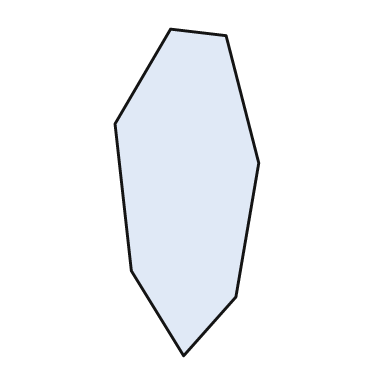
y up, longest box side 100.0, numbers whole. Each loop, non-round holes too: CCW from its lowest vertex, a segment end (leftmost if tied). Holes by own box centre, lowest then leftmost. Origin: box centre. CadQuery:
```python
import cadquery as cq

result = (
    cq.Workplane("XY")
    .moveTo(-1.0, -50.0)
    .lineTo(15.0, -32.0)
    .lineTo(22.0, 9.0)
    .lineTo(12.0, 48.0)
    .lineTo(-5.0, 50.0)
    .lineTo(-22.0, 21.0)
    .lineTo(-17.0, -24.0)
    .close()
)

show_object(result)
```